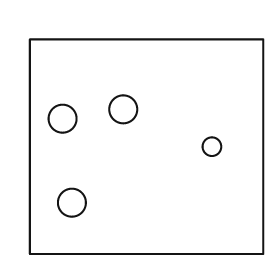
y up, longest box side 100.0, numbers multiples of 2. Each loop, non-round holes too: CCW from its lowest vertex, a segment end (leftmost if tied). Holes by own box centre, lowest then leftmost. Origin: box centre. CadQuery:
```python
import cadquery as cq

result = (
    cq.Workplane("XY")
    .moveTo(-50.0, -46.0)
    .lineTo(50.0, -46.0)
    .lineTo(50.0, 46.0)
    .lineTo(-50.0, 46.0)
    .close()
    .moveTo(-32.0, -24.0)
    .circle(6.0)
    .moveTo(28.0, 0.0)
    .circle(4.0)
    .moveTo(-36.0, 12.0)
    .circle(6.0)
    .moveTo(-10.0, 16.0)
    .circle(6.0)
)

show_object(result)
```